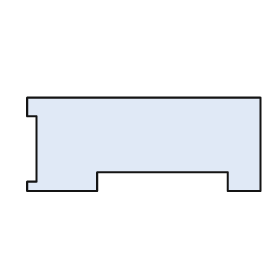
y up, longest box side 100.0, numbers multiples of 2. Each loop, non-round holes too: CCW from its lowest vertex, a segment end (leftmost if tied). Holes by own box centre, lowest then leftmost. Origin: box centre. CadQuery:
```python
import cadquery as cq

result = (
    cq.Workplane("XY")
    .moveTo(-50.0, -20.0)
    .lineTo(-20.0, -20.0)
    .lineTo(-20.0, -12.0)
    .lineTo(36.0, -12.0)
    .lineTo(36.0, -20.0)
    .lineTo(50.0, -20.0)
    .lineTo(50.0, 20.0)
    .lineTo(-50.0, 20.0)
    .lineTo(-50.0, 12.0)
    .lineTo(-46.0, 12.0)
    .lineTo(-46.0, -16.0)
    .lineTo(-50.0, -16.0)
    .close()
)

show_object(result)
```